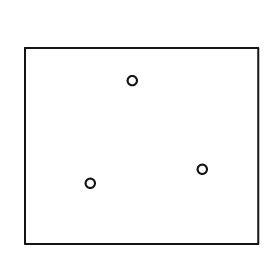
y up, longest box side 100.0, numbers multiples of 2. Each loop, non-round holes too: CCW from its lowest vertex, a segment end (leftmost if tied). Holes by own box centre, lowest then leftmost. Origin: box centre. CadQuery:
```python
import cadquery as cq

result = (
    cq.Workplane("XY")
    .moveTo(-50.0, -42.0)
    .lineTo(50.0, -42.0)
    .lineTo(50.0, 42.0)
    .lineTo(-50.0, 42.0)
    .close()
    .moveTo(-22.0, -16.0)
    .circle(2.0)
    .moveTo(26.0, -10.0)
    .circle(2.0)
    .moveTo(-4.0, 28.0)
    .circle(2.0)
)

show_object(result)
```